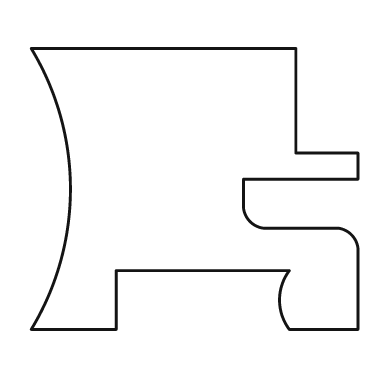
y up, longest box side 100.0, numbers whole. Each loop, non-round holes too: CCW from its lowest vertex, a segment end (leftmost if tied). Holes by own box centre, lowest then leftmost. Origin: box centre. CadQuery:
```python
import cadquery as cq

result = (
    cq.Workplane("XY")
    .moveTo(-50.0, -43.0)
    .lineTo(-24.0, -43.0)
    .lineTo(-24.0, -25.0)
    .lineTo(29.0, -25.0)
    .threePointArc((26.0, -34.0), (29.0, -43.0))
    .lineTo(50.0, -43.0)
    .lineTo(50.0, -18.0)
    .threePointArc((48.0, -14.0), (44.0, -12.0))
    .lineTo(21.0, -12.0)
    .threePointArc((17.0, -10.0), (15.0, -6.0))
    .lineTo(15.0, 3.0)
    .lineTo(50.0, 3.0)
    .lineTo(50.0, 11.0)
    .lineTo(31.0, 11.0)
    .lineTo(31.0, 43.0)
    .lineTo(-50.0, 43.0)
    .threePointArc((-38.0, 0.0), (-50.0, -43.0))
    .close()
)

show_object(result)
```